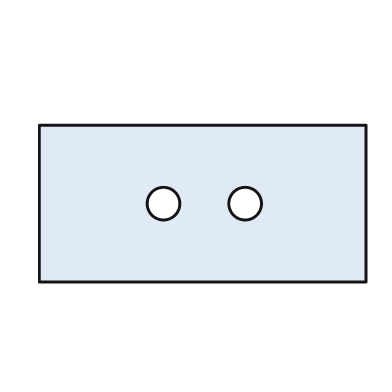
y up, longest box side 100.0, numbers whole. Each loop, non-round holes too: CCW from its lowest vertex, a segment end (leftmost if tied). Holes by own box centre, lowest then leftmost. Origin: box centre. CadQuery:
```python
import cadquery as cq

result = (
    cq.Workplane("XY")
    .moveTo(-50.0, -24.0)
    .lineTo(50.0, -24.0)
    .lineTo(50.0, 24.0)
    .lineTo(-50.0, 24.0)
    .close()
    .moveTo(-12.0, 0.0)
    .circle(5.0)
    .moveTo(13.0, 0.0)
    .circle(5.0)
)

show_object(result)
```